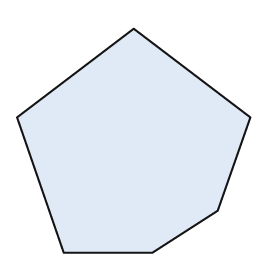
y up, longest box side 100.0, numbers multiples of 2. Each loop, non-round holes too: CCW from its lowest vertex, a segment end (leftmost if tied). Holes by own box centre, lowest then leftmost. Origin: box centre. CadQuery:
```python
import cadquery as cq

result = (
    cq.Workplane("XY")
    .moveTo(-30.0, -48.0)
    .lineTo(8.0, -48.0)
    .lineTo(36.0, -30.0)
    .lineTo(50.0, 10.0)
    .lineTo(0.0, 48.0)
    .lineTo(-50.0, 10.0)
    .close()
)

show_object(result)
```